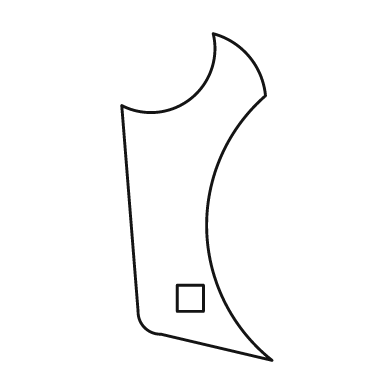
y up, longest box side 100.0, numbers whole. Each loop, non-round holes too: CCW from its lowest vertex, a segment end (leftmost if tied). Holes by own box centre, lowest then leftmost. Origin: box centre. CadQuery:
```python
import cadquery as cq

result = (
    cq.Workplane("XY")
    .moveTo(23.0, -50.0)
    .threePointArc((3.0, -10.0), (21.0, 31.0))
    .threePointArc((16.0, 43.0), (5.0, 50.0))
    .threePointArc((-2.0, 30.0), (-23.0, 28.0))
    .lineTo(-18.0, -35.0)
    .threePointArc((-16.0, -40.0), (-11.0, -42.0))
    .close()
    .moveTo(-6.0, -35.0)
    .lineTo(2.0, -35.0)
    .lineTo(2.0, -27.0)
    .lineTo(-6.0, -27.0)
    .close()
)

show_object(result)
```